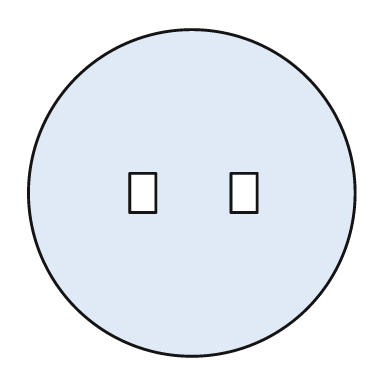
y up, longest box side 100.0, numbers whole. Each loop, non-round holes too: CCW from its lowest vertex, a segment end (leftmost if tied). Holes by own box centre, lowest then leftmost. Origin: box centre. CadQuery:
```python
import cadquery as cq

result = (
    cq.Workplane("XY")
    .moveTo(0.0, 0.0)
    .circle(50.0)
    .moveTo(-19.0, -6.0)
    .lineTo(-11.0, -6.0)
    .lineTo(-11.0, 6.0)
    .lineTo(-19.0, 6.0)
    .close()
    .moveTo(12.0, -6.0)
    .lineTo(20.0, -6.0)
    .lineTo(20.0, 6.0)
    .lineTo(12.0, 6.0)
    .close()
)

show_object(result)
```